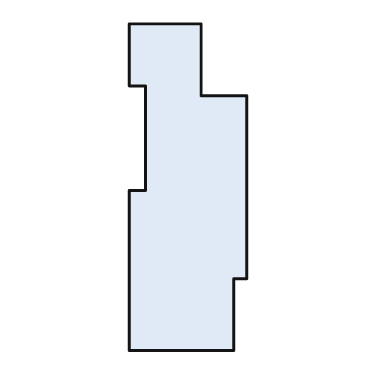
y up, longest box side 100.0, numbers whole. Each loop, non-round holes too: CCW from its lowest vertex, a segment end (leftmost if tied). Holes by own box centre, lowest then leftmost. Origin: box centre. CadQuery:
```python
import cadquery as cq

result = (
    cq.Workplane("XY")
    .moveTo(-18.0, -50.0)
    .lineTo(14.0, -50.0)
    .lineTo(14.0, -28.0)
    .lineTo(18.0, -28.0)
    .lineTo(18.0, 28.0)
    .lineTo(4.0, 28.0)
    .lineTo(4.0, 50.0)
    .lineTo(-18.0, 50.0)
    .lineTo(-18.0, 31.0)
    .lineTo(-13.0, 31.0)
    .lineTo(-13.0, -1.0)
    .lineTo(-18.0, -1.0)
    .close()
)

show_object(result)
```